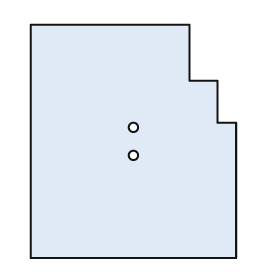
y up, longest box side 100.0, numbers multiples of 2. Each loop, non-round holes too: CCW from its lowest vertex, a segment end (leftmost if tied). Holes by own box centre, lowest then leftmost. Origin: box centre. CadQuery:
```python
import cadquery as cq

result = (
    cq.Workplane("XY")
    .moveTo(-44.0, -50.0)
    .lineTo(44.0, -50.0)
    .lineTo(44.0, 8.0)
    .lineTo(36.0, 8.0)
    .lineTo(36.0, 26.0)
    .lineTo(24.0, 26.0)
    .lineTo(24.0, 50.0)
    .lineTo(-44.0, 50.0)
    .close()
    .moveTo(0.0, -6.0)
    .circle(2.0)
    .moveTo(0.0, 6.0)
    .circle(2.0)
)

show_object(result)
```